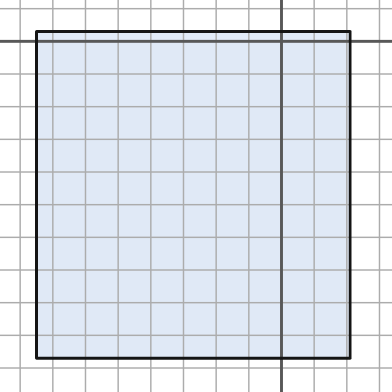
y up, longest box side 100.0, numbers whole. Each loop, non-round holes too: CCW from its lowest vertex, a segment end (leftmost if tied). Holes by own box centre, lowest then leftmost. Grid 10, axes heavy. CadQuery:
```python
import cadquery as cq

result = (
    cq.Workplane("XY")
    .moveTo(-75.0, -97.0)
    .lineTo(21.0, -97.0)
    .lineTo(21.0, 3.0)
    .lineTo(-75.0, 3.0)
    .close()
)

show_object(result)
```